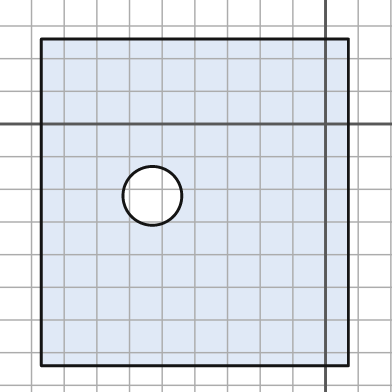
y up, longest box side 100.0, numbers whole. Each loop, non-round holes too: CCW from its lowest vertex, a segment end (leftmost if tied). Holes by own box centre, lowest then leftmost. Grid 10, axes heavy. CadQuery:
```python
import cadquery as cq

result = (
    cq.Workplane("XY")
    .moveTo(-87.0, -74.0)
    .lineTo(7.0, -74.0)
    .lineTo(7.0, 26.0)
    .lineTo(-87.0, 26.0)
    .close()
    .moveTo(-53.0, -22.0)
    .circle(9.0)
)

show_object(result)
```